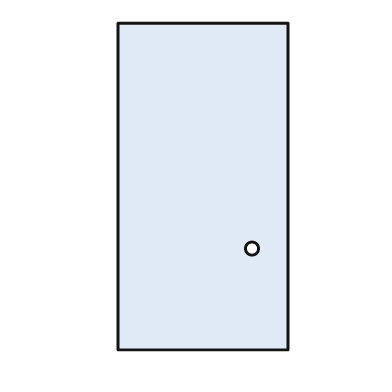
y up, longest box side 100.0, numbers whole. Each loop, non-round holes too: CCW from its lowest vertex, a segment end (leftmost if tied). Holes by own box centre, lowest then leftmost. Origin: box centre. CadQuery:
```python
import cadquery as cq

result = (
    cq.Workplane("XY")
    .moveTo(-26.0, -50.0)
    .lineTo(26.0, -50.0)
    .lineTo(26.0, 50.0)
    .lineTo(-26.0, 50.0)
    .close()
    .moveTo(15.0, -19.0)
    .circle(2.0)
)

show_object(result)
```